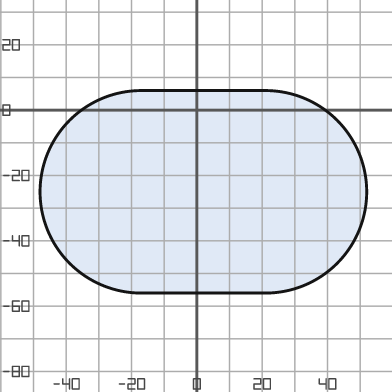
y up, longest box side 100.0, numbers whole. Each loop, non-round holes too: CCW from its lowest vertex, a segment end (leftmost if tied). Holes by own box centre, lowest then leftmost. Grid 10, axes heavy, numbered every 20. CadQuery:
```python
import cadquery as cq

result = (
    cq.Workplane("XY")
    .moveTo(-17.0, -56.0)
    .lineTo(21.0, -56.0)
    .threePointArc((52.0, -25.0), (21.0, 6.0))
    .lineTo(-17.0, 6.0)
    .threePointArc((-48.0, -25.0), (-17.0, -56.0))
    .close()
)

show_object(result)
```